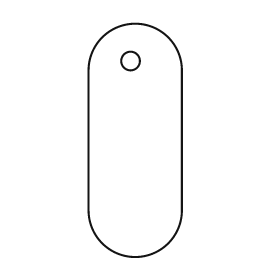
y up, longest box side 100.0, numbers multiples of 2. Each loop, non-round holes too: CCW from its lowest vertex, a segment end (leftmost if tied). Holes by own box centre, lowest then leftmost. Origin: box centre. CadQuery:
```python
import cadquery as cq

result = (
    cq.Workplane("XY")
    .moveTo(-20.0, -30.0)
    .threePointArc((0.0, -50.0), (20.0, -30.0))
    .lineTo(20.0, 30.0)
    .threePointArc((0.0, 50.0), (-20.0, 30.0))
    .close()
    .moveTo(-2.0, 34.0)
    .circle(4.0)
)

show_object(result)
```